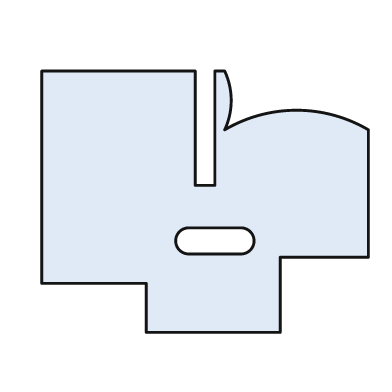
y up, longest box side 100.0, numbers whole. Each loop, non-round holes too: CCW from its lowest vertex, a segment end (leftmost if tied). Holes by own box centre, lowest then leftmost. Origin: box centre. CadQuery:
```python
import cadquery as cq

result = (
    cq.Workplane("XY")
    .moveTo(-18.0, -40.0)
    .lineTo(23.0, -40.0)
    .lineTo(23.0, -17.0)
    .lineTo(50.0, -17.0)
    .lineTo(50.0, 22.0)
    .threePointArc((28.0, 28.0), (6.0, 22.0))
    .threePointArc((8.0, 31.0), (6.0, 40.0))
    .lineTo(3.0, 40.0)
    .lineTo(3.0, 5.0)
    .lineTo(-3.0, 5.0)
    .lineTo(-3.0, 40.0)
    .lineTo(-50.0, 40.0)
    .lineTo(-50.0, -25.0)
    .lineTo(-18.0, -25.0)
    .close()
    .moveTo(-5.0, -16.0)
    .lineTo(11.0, -16.0)
    .threePointArc((15.0, -12.0), (11.0, -8.0))
    .lineTo(-5.0, -8.0)
    .threePointArc((-9.0, -12.0), (-5.0, -16.0))
    .close()
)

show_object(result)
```